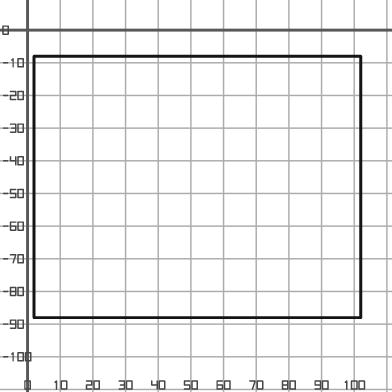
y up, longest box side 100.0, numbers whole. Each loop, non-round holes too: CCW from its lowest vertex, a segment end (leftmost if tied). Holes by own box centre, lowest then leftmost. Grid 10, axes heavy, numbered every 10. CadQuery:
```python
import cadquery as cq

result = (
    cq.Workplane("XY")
    .moveTo(2.0, -88.0)
    .lineTo(102.0, -88.0)
    .lineTo(102.0, -8.0)
    .lineTo(2.0, -8.0)
    .close()
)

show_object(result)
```